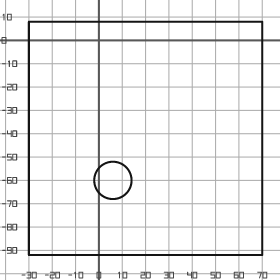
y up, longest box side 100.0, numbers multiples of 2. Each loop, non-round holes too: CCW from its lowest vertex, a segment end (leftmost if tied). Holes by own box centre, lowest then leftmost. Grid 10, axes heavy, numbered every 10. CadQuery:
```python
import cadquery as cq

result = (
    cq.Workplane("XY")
    .moveTo(-30.0, -92.0)
    .lineTo(70.0, -92.0)
    .lineTo(70.0, 8.0)
    .lineTo(-30.0, 8.0)
    .close()
    .moveTo(6.0, -60.0)
    .circle(8.0)
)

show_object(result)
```